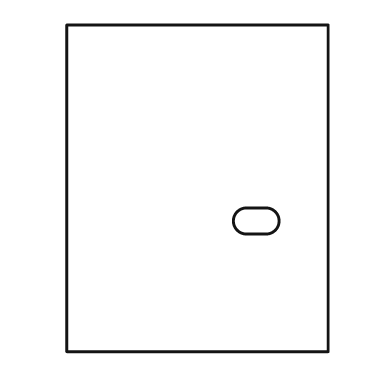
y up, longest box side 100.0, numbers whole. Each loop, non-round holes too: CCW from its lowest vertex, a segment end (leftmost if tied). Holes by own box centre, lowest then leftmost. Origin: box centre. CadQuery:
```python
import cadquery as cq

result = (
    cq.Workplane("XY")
    .moveTo(-40.0, -50.0)
    .lineTo(40.0, -50.0)
    .lineTo(40.0, 50.0)
    .lineTo(-40.0, 50.0)
    .close()
    .moveTo(15.0, -14.0)
    .lineTo(21.0, -14.0)
    .threePointArc((25.0, -10.0), (21.0, -6.0))
    .lineTo(15.0, -6.0)
    .threePointArc((11.0, -10.0), (15.0, -14.0))
    .close()
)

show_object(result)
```